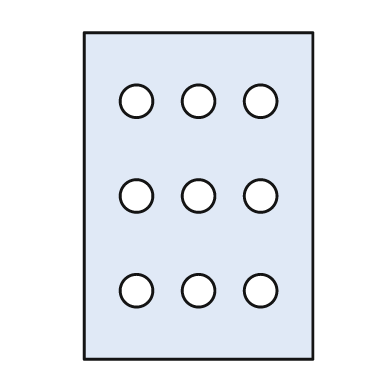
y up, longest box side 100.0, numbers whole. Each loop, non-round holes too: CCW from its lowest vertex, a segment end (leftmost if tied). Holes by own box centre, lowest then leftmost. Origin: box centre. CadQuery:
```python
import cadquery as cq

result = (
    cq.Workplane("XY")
    .moveTo(-35.0, -50.0)
    .lineTo(35.0, -50.0)
    .lineTo(35.0, 50.0)
    .lineTo(-35.0, 50.0)
    .close()
    .moveTo(-19.0, -29.0)
    .circle(5.0)
    .moveTo(0.0, -29.0)
    .circle(5.0)
    .moveTo(19.0, -29.0)
    .circle(5.0)
    .moveTo(-19.0, 0.0)
    .circle(5.0)
    .moveTo(0.0, 0.0)
    .circle(5.0)
    .moveTo(19.0, 0.0)
    .circle(5.0)
    .moveTo(-19.0, 29.0)
    .circle(5.0)
    .moveTo(0.0, 29.0)
    .circle(5.0)
    .moveTo(19.0, 29.0)
    .circle(5.0)
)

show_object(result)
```